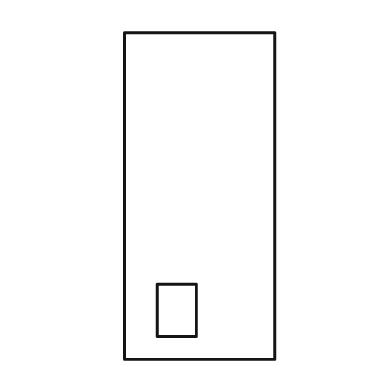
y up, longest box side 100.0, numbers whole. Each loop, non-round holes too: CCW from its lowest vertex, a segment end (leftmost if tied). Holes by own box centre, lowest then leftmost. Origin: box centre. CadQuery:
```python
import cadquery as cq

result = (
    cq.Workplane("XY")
    .moveTo(-23.0, -50.0)
    .lineTo(23.0, -50.0)
    .lineTo(23.0, 50.0)
    .lineTo(-23.0, 50.0)
    .close()
    .moveTo(-13.0, -43.0)
    .lineTo(-1.0, -43.0)
    .lineTo(-1.0, -27.0)
    .lineTo(-13.0, -27.0)
    .close()
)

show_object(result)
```